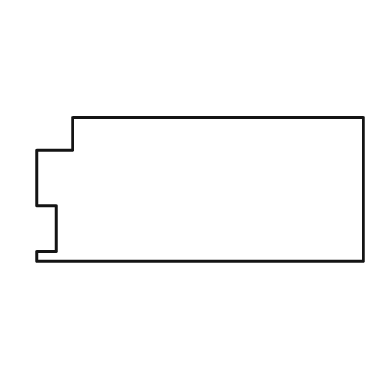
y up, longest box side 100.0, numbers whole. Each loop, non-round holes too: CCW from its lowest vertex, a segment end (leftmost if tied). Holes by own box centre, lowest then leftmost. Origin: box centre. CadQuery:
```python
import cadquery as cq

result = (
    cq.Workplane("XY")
    .moveTo(-50.0, -22.0)
    .lineTo(50.0, -22.0)
    .lineTo(50.0, 22.0)
    .lineTo(-39.0, 22.0)
    .lineTo(-39.0, 12.0)
    .lineTo(-50.0, 12.0)
    .lineTo(-50.0, -5.0)
    .lineTo(-44.0, -5.0)
    .lineTo(-44.0, -19.0)
    .lineTo(-50.0, -19.0)
    .close()
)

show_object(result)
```